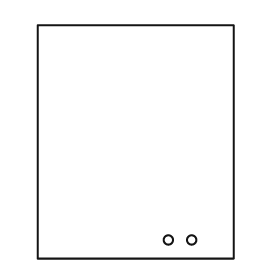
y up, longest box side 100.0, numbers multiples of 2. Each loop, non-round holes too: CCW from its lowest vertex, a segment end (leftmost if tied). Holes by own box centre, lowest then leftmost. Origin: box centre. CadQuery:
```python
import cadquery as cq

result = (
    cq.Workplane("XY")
    .moveTo(-42.0, -50.0)
    .lineTo(42.0, -50.0)
    .lineTo(42.0, 50.0)
    .lineTo(-42.0, 50.0)
    .close()
    .moveTo(14.0, -42.0)
    .circle(2.0)
    .moveTo(24.0, -42.0)
    .circle(2.0)
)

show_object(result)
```